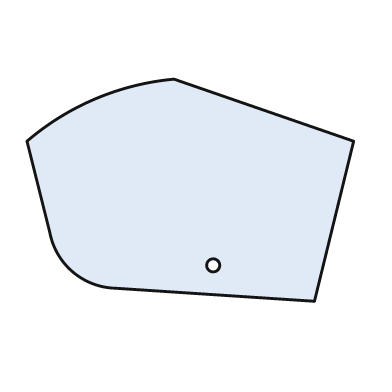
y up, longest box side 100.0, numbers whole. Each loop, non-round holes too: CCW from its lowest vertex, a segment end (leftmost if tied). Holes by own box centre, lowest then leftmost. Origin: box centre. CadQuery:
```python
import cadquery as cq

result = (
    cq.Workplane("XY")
    .moveTo(38.0, -34.0)
    .lineTo(50.0, 15.0)
    .lineTo(-5.0, 34.0)
    .threePointArc((-29.0, 28.0), (-50.0, 15.0))
    .lineTo(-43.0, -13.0)
    .threePointArc((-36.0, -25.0), (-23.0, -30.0))
    .close()
    .moveTo(7.0, -23.0)
    .circle(2.0)
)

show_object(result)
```